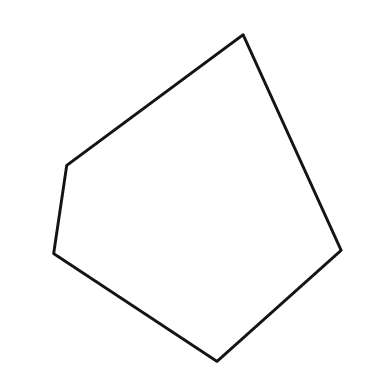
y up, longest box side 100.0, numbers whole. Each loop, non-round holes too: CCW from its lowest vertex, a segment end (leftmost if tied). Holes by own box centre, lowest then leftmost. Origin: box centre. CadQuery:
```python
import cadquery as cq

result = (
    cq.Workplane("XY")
    .moveTo(6.0, -50.0)
    .lineTo(44.0, -16.0)
    .lineTo(14.0, 50.0)
    .lineTo(-40.0, 10.0)
    .lineTo(-44.0, -17.0)
    .close()
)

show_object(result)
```